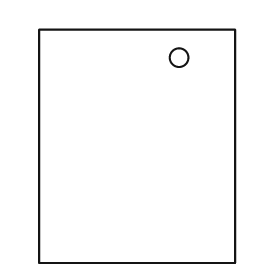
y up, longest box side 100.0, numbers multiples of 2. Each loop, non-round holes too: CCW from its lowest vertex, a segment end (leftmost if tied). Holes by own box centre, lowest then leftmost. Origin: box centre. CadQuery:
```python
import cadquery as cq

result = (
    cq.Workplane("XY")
    .moveTo(-42.0, -50.0)
    .lineTo(42.0, -50.0)
    .lineTo(42.0, 50.0)
    .lineTo(-42.0, 50.0)
    .close()
    .moveTo(18.0, 38.0)
    .circle(4.0)
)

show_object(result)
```